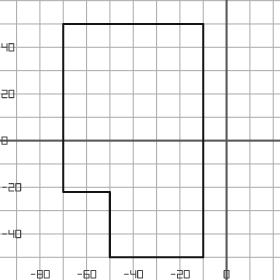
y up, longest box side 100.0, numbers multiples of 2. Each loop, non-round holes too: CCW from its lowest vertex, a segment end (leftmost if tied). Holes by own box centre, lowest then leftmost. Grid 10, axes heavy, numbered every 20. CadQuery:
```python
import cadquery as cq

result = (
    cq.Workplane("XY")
    .moveTo(-50.0, -50.0)
    .lineTo(-10.0, -50.0)
    .lineTo(-10.0, 50.0)
    .lineTo(-70.0, 50.0)
    .lineTo(-70.0, -22.0)
    .lineTo(-50.0, -22.0)
    .close()
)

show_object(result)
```